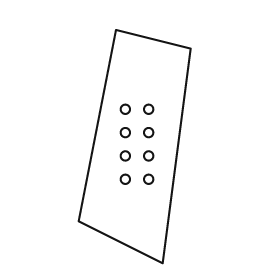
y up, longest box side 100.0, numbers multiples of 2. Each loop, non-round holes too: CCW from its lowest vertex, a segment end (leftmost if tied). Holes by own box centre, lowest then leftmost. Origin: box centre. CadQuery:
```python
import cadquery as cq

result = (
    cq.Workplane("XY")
    .moveTo(12.0, -50.0)
    .lineTo(24.0, 42.0)
    .lineTo(-8.0, 50.0)
    .lineTo(-24.0, -32.0)
    .close()
    .moveTo(-4.0, -14.0)
    .circle(2.0)
    .moveTo(6.0, -14.0)
    .circle(2.0)
    .moveTo(-4.0, -4.0)
    .circle(2.0)
    .moveTo(6.0, -4.0)
    .circle(2.0)
    .moveTo(-4.0, 6.0)
    .circle(2.0)
    .moveTo(6.0, 6.0)
    .circle(2.0)
    .moveTo(-4.0, 16.0)
    .circle(2.0)
    .moveTo(6.0, 16.0)
    .circle(2.0)
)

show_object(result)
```